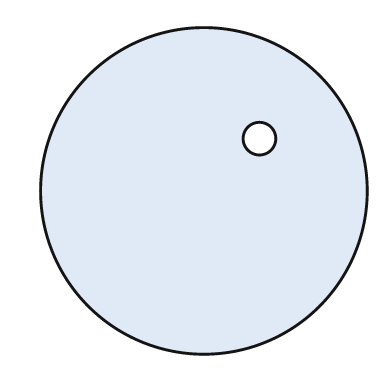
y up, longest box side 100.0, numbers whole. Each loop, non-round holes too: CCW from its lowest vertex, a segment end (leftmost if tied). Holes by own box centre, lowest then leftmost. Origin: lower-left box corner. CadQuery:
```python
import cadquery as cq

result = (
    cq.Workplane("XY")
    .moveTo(50.0, 50.0)
    .circle(50.0)
    .moveTo(67.0, 66.0)
    .circle(5.0)
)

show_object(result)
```